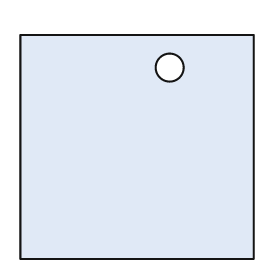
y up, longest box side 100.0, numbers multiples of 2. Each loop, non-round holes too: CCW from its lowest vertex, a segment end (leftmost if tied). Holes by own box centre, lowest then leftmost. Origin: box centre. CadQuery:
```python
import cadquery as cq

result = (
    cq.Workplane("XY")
    .moveTo(-50.0, -48.0)
    .lineTo(50.0, -48.0)
    .lineTo(50.0, 48.0)
    .lineTo(-50.0, 48.0)
    .close()
    .moveTo(14.0, 34.0)
    .circle(6.0)
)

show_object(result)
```